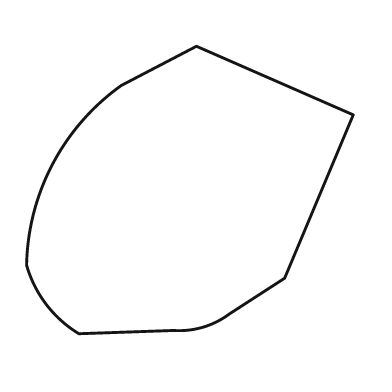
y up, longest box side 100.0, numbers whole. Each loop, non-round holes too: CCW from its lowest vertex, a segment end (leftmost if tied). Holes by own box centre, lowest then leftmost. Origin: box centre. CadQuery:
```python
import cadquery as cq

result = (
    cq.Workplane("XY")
    .moveTo(-34.0, -44.0)
    .lineTo(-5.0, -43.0)
    .threePointArc((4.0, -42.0), (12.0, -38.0))
    .lineTo(29.0, -27.0)
    .lineTo(50.0, 23.0)
    .lineTo(2.0, 44.0)
    .lineTo(-21.0, 32.0)
    .threePointArc((-42.0, 8.0), (-50.0, -23.0))
    .threePointArc((-44.0, -35.0), (-34.0, -44.0))
    .close()
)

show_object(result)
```